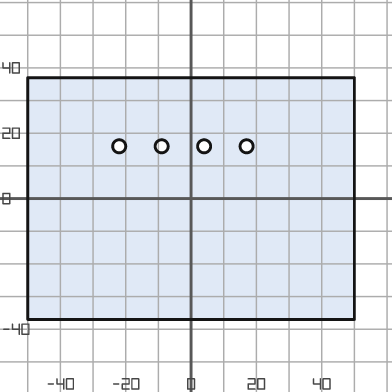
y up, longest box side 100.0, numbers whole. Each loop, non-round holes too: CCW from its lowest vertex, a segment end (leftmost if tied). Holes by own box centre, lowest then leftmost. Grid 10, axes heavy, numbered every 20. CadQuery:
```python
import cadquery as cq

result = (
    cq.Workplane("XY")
    .moveTo(-50.0, -37.0)
    .lineTo(50.0, -37.0)
    .lineTo(50.0, 37.0)
    .lineTo(-50.0, 37.0)
    .close()
    .moveTo(-22.0, 16.0)
    .circle(2.0)
    .moveTo(-9.0, 16.0)
    .circle(2.0)
    .moveTo(4.0, 16.0)
    .circle(2.0)
    .moveTo(17.0, 16.0)
    .circle(2.0)
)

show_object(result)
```